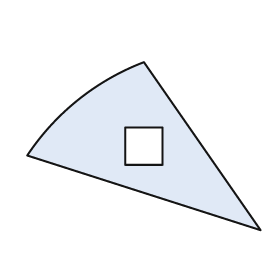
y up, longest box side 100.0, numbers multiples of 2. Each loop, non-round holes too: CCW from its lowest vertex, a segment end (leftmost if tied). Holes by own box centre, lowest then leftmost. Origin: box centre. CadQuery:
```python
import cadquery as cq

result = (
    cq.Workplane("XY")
    .moveTo(50.0, -36.0)
    .lineTo(0.0, 36.0)
    .threePointArc((-28.0, 20.0), (-50.0, -4.0))
    .close()
    .moveTo(-8.0, -8.0)
    .lineTo(8.0, -8.0)
    .lineTo(8.0, 8.0)
    .lineTo(-8.0, 8.0)
    .close()
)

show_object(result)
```